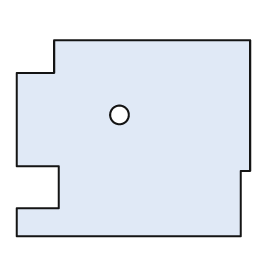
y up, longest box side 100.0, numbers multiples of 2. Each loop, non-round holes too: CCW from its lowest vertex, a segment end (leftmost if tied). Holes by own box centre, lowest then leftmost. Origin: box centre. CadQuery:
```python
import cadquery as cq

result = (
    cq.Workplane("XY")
    .moveTo(-50.0, -42.0)
    .lineTo(46.0, -42.0)
    .lineTo(46.0, -14.0)
    .lineTo(50.0, -14.0)
    .lineTo(50.0, 42.0)
    .lineTo(-34.0, 42.0)
    .lineTo(-34.0, 28.0)
    .lineTo(-50.0, 28.0)
    .lineTo(-50.0, -12.0)
    .lineTo(-32.0, -12.0)
    .lineTo(-32.0, -30.0)
    .lineTo(-50.0, -30.0)
    .close()
    .moveTo(-6.0, 10.0)
    .circle(4.0)
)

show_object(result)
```